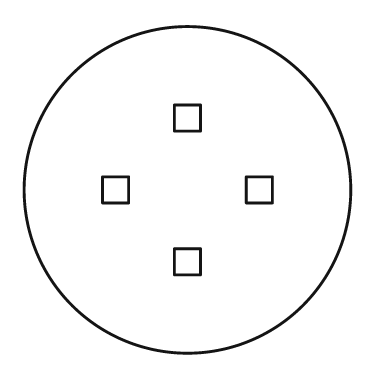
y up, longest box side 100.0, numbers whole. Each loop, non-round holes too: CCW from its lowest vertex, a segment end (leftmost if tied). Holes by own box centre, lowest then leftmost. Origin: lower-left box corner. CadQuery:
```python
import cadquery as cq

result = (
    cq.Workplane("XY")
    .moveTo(50.0, 50.0)
    .circle(50.0)
    .moveTo(46.0, 24.0)
    .lineTo(54.0, 24.0)
    .lineTo(54.0, 32.0)
    .lineTo(46.0, 32.0)
    .close()
    .moveTo(24.0, 46.0)
    .lineTo(32.0, 46.0)
    .lineTo(32.0, 54.0)
    .lineTo(24.0, 54.0)
    .close()
    .moveTo(68.0, 46.0)
    .lineTo(76.0, 46.0)
    .lineTo(76.0, 54.0)
    .lineTo(68.0, 54.0)
    .close()
    .moveTo(46.0, 68.0)
    .lineTo(54.0, 68.0)
    .lineTo(54.0, 76.0)
    .lineTo(46.0, 76.0)
    .close()
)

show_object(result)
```